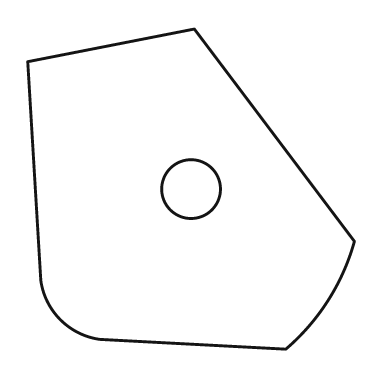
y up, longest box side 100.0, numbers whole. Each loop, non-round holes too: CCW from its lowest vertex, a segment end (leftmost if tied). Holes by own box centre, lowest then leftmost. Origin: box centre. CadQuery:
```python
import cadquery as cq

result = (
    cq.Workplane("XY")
    .moveTo(29.0, -49.0)
    .threePointArc((42.0, -34.0), (50.0, -16.0))
    .lineTo(1.0, 49.0)
    .lineTo(-50.0, 39.0)
    .lineTo(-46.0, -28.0)
    .threePointArc((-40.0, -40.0), (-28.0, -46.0))
    .close()
    .moveTo(0.0, 0.0)
    .circle(9.0)
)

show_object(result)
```